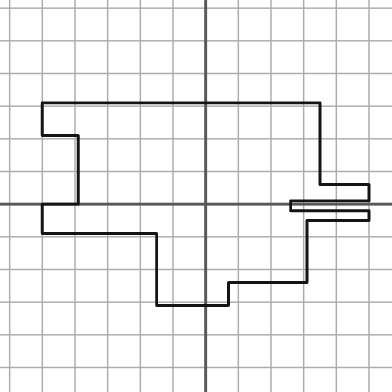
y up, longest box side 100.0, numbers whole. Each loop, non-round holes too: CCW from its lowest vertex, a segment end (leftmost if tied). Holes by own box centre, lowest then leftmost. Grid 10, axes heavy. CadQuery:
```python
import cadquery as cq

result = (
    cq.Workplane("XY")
    .moveTo(-15.0, -31.0)
    .lineTo(7.0, -31.0)
    .lineTo(7.0, -24.0)
    .lineTo(31.0, -24.0)
    .lineTo(31.0, -5.0)
    .lineTo(50.0, -5.0)
    .lineTo(50.0, -2.0)
    .lineTo(26.0, -2.0)
    .lineTo(26.0, 1.0)
    .lineTo(50.0, 1.0)
    .lineTo(50.0, 6.0)
    .lineTo(35.0, 6.0)
    .lineTo(35.0, 31.0)
    .lineTo(-50.0, 31.0)
    .lineTo(-50.0, 21.0)
    .lineTo(-39.0, 21.0)
    .lineTo(-39.0, 0.0)
    .lineTo(-50.0, 0.0)
    .lineTo(-50.0, -9.0)
    .lineTo(-15.0, -9.0)
    .close()
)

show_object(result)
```